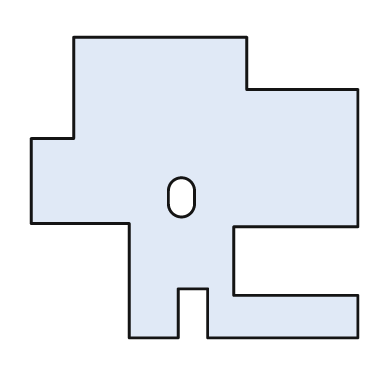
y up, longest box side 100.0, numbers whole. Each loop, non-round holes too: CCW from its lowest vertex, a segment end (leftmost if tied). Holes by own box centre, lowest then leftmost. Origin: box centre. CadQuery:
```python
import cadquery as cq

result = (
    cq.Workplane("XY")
    .moveTo(-20.0, -46.0)
    .lineTo(-5.0, -46.0)
    .lineTo(-5.0, -31.0)
    .lineTo(4.0, -31.0)
    .lineTo(4.0, -46.0)
    .lineTo(50.0, -46.0)
    .lineTo(50.0, -33.0)
    .lineTo(12.0, -33.0)
    .lineTo(12.0, -12.0)
    .lineTo(50.0, -12.0)
    .lineTo(50.0, 30.0)
    .lineTo(16.0, 30.0)
    .lineTo(16.0, 46.0)
    .lineTo(-37.0, 46.0)
    .lineTo(-37.0, 15.0)
    .lineTo(-50.0, 15.0)
    .lineTo(-50.0, -11.0)
    .lineTo(-20.0, -11.0)
    .close()
    .moveTo(-8.0, -5.0)
    .threePointArc((-4.0, -9.0), (0.0, -5.0))
    .lineTo(0.0, -1.0)
    .threePointArc((-4.0, 3.0), (-8.0, -1.0))
    .close()
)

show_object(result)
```